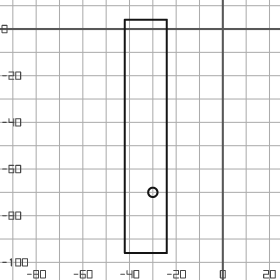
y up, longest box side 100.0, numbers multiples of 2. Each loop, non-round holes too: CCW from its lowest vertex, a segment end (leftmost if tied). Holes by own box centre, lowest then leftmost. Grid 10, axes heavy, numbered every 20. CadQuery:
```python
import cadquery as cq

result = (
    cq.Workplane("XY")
    .moveTo(-42.0, -96.0)
    .lineTo(-24.0, -96.0)
    .lineTo(-24.0, 4.0)
    .lineTo(-42.0, 4.0)
    .close()
    .moveTo(-30.0, -70.0)
    .circle(2.0)
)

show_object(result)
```